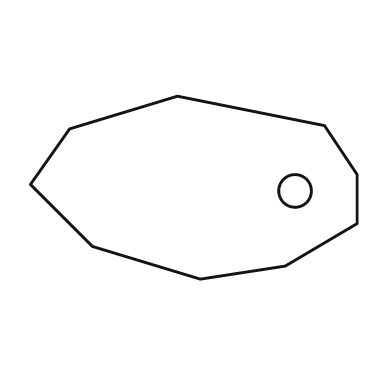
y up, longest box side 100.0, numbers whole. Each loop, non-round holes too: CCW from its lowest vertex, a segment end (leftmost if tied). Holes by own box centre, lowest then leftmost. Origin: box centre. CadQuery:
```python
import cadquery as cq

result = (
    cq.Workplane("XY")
    .moveTo(2.0, -28.0)
    .lineTo(28.0, -24.0)
    .lineTo(50.0, -11.0)
    .lineTo(50.0, 4.0)
    .lineTo(40.0, 19.0)
    .lineTo(-5.0, 28.0)
    .lineTo(-38.0, 18.0)
    .lineTo(-50.0, 1.0)
    .lineTo(-31.0, -18.0)
    .close()
    .moveTo(31.0, -1.0)
    .circle(5.0)
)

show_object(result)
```